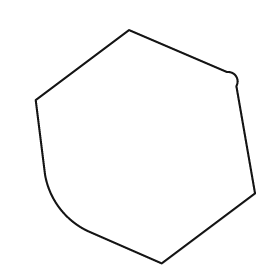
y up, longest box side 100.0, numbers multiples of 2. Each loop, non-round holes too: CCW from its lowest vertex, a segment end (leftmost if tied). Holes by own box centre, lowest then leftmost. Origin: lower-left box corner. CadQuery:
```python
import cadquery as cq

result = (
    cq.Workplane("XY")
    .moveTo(54.0, 0.0)
    .lineTo(94.0, 30.0)
    .lineTo(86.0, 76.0)
    .threePointArc((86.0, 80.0), (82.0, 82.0))
    .lineTo(40.0, 100.0)
    .lineTo(0.0, 70.0)
    .lineTo(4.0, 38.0)
    .threePointArc((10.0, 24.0), (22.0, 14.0))
    .close()
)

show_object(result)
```